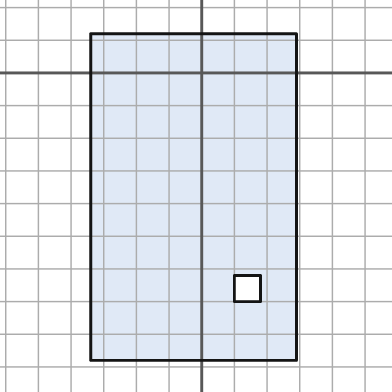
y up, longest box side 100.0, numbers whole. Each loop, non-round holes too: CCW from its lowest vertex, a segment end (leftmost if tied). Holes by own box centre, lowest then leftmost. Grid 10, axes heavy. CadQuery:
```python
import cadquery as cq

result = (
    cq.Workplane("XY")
    .moveTo(-34.0, -88.0)
    .lineTo(29.0, -88.0)
    .lineTo(29.0, 12.0)
    .lineTo(-34.0, 12.0)
    .close()
    .moveTo(10.0, -70.0)
    .lineTo(18.0, -70.0)
    .lineTo(18.0, -62.0)
    .lineTo(10.0, -62.0)
    .close()
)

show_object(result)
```